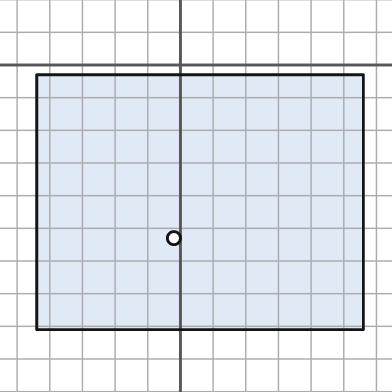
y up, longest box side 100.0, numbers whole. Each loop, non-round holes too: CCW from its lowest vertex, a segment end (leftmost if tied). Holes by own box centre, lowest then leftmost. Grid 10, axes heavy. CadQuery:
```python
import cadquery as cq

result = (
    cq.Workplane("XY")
    .moveTo(-44.0, -81.0)
    .lineTo(56.0, -81.0)
    .lineTo(56.0, -3.0)
    .lineTo(-44.0, -3.0)
    .close()
    .moveTo(-2.0, -53.0)
    .circle(2.0)
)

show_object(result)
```